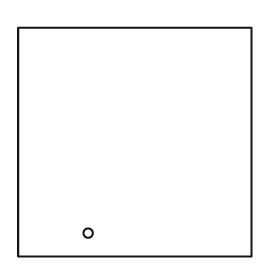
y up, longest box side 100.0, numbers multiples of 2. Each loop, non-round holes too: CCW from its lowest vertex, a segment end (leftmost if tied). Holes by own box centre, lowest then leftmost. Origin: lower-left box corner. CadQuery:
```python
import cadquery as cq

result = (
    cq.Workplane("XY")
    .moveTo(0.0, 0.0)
    .lineTo(100.0, 0.0)
    .lineTo(100.0, 98.0)
    .lineTo(0.0, 98.0)
    .close()
    .moveTo(30.0, 10.0)
    .circle(2.0)
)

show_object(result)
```